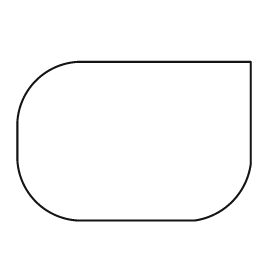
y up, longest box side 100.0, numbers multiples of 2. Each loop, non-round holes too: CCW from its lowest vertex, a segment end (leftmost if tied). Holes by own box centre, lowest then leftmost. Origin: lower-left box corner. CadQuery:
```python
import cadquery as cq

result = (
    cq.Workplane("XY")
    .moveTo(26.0, 0.0)
    .lineTo(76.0, 0.0)
    .threePointArc((92.0, 8.0), (100.0, 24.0))
    .lineTo(100.0, 68.0)
    .lineTo(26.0, 68.0)
    .threePointArc((8.0, 60.0), (0.0, 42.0))
    .lineTo(0.0, 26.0)
    .threePointArc((8.0, 8.0), (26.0, 0.0))
    .close()
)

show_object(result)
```